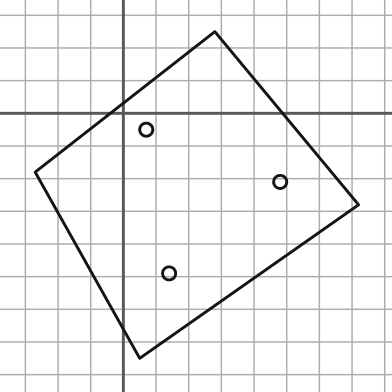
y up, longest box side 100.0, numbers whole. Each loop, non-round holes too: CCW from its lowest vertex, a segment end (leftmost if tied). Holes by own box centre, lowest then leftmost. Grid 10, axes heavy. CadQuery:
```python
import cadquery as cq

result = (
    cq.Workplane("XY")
    .moveTo(5.0, -75.0)
    .lineTo(72.0, -28.0)
    .lineTo(28.0, 25.0)
    .lineTo(-27.0, -18.0)
    .close()
    .moveTo(14.0, -49.0)
    .circle(2.0)
    .moveTo(48.0, -21.0)
    .circle(2.0)
    .moveTo(7.0, -5.0)
    .circle(2.0)
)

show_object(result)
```